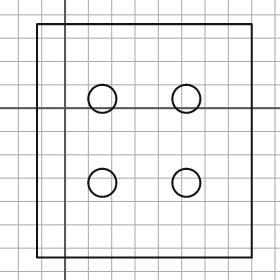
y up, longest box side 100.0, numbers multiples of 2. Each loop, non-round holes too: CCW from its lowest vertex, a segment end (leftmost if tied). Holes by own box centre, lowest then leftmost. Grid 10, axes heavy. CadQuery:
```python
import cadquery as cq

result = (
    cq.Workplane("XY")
    .moveTo(-12.0, -64.0)
    .lineTo(80.0, -64.0)
    .lineTo(80.0, 36.0)
    .lineTo(-12.0, 36.0)
    .close()
    .moveTo(16.0, -32.0)
    .circle(6.0)
    .moveTo(52.0, -32.0)
    .circle(6.0)
    .moveTo(16.0, 4.0)
    .circle(6.0)
    .moveTo(52.0, 4.0)
    .circle(6.0)
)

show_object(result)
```